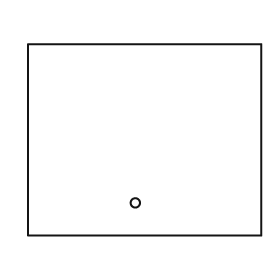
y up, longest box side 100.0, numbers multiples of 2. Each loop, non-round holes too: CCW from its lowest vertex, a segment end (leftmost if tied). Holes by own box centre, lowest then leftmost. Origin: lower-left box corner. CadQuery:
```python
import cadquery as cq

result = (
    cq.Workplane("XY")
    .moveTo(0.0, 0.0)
    .lineTo(100.0, 0.0)
    .lineTo(100.0, 82.0)
    .lineTo(0.0, 82.0)
    .close()
    .moveTo(46.0, 14.0)
    .circle(2.0)
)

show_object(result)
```